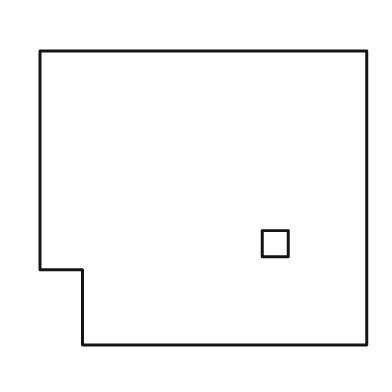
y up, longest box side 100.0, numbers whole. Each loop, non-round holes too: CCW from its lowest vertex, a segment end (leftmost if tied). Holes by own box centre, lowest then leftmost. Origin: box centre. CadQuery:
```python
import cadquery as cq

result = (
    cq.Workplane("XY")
    .moveTo(-37.0, -45.0)
    .lineTo(50.0, -45.0)
    .lineTo(50.0, 45.0)
    .lineTo(-50.0, 45.0)
    .lineTo(-50.0, -22.0)
    .lineTo(-37.0, -22.0)
    .close()
    .moveTo(18.0, -18.0)
    .lineTo(26.0, -18.0)
    .lineTo(26.0, -10.0)
    .lineTo(18.0, -10.0)
    .close()
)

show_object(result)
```